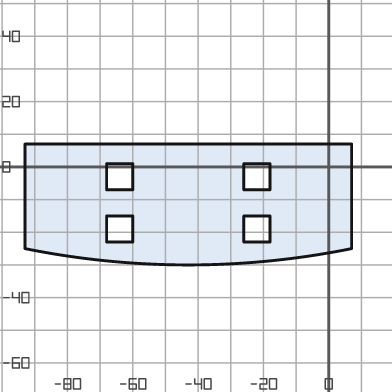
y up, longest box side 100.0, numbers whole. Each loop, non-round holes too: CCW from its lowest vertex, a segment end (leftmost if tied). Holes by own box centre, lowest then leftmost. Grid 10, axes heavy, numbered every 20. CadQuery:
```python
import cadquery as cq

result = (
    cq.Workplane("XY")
    .moveTo(-93.0, -25.0)
    .threePointArc((-43.0, -30.0), (7.0, -25.0))
    .lineTo(7.0, 7.0)
    .lineTo(-93.0, 7.0)
    .close()
    .moveTo(-68.0, -23.0)
    .lineTo(-60.0, -23.0)
    .lineTo(-60.0, -15.0)
    .lineTo(-68.0, -15.0)
    .close()
    .moveTo(-26.0, -23.0)
    .lineTo(-18.0, -23.0)
    .lineTo(-18.0, -15.0)
    .lineTo(-26.0, -15.0)
    .close()
    .moveTo(-68.0, -7.0)
    .lineTo(-60.0, -7.0)
    .lineTo(-60.0, 1.0)
    .lineTo(-68.0, 1.0)
    .close()
    .moveTo(-26.0, -7.0)
    .lineTo(-18.0, -7.0)
    .lineTo(-18.0, 1.0)
    .lineTo(-26.0, 1.0)
    .close()
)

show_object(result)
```